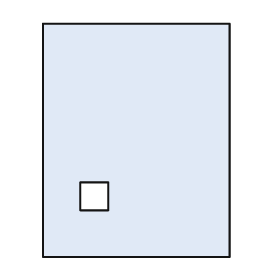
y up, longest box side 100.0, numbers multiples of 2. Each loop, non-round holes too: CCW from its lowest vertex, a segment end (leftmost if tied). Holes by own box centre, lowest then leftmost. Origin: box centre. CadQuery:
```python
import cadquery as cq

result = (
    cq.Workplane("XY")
    .moveTo(-40.0, -50.0)
    .lineTo(40.0, -50.0)
    .lineTo(40.0, 50.0)
    .lineTo(-40.0, 50.0)
    .close()
    .moveTo(-24.0, -30.0)
    .lineTo(-12.0, -30.0)
    .lineTo(-12.0, -18.0)
    .lineTo(-24.0, -18.0)
    .close()
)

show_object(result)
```